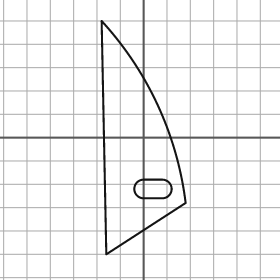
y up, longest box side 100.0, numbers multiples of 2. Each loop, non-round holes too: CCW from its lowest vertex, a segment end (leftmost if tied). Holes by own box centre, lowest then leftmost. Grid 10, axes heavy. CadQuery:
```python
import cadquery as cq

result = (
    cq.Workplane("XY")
    .moveTo(-16.0, -50.0)
    .lineTo(18.0, -28.0)
    .threePointArc((6.0, 14.0), (-18.0, 50.0))
    .close()
    .moveTo(0.0, -26.0)
    .lineTo(8.0, -26.0)
    .threePointArc((12.0, -22.0), (8.0, -18.0))
    .lineTo(0.0, -18.0)
    .threePointArc((-4.0, -22.0), (0.0, -26.0))
    .close()
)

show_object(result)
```